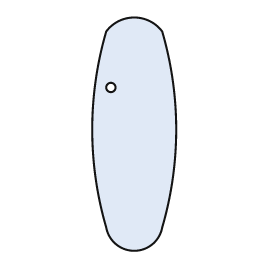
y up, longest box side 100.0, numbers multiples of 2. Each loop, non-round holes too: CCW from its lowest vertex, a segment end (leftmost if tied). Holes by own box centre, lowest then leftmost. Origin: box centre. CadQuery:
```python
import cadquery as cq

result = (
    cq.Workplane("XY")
    .moveTo(-12.0, -40.0)
    .threePointArc((0.0, -50.0), (12.0, -40.0))
    .threePointArc((18.0, 2.0), (12.0, 44.0))
    .threePointArc((0.0, 50.0), (-12.0, 44.0))
    .threePointArc((-18.0, 2.0), (-12.0, -40.0))
    .close()
    .moveTo(-10.0, 20.0)
    .circle(2.0)
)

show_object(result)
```